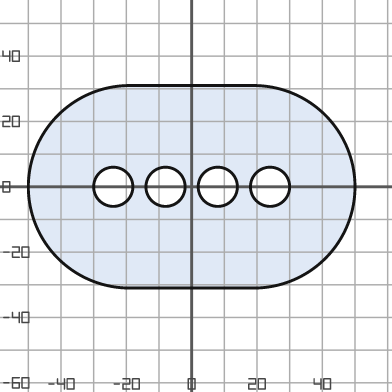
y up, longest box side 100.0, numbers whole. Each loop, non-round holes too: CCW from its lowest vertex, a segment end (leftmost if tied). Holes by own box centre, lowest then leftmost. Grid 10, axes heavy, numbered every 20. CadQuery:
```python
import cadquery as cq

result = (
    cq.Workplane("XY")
    .moveTo(-19.0, -31.0)
    .lineTo(19.0, -31.0)
    .threePointArc((50.0, 0.0), (19.0, 31.0))
    .lineTo(-19.0, 31.0)
    .threePointArc((-50.0, 0.0), (-19.0, -31.0))
    .close()
    .moveTo(-24.0, 0.0)
    .circle(6.0)
    .moveTo(-8.0, 0.0)
    .circle(6.0)
    .moveTo(8.0, 0.0)
    .circle(6.0)
    .moveTo(24.0, 0.0)
    .circle(6.0)
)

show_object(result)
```